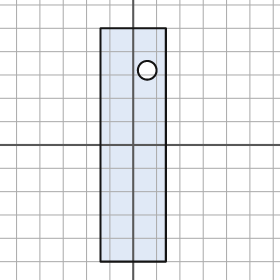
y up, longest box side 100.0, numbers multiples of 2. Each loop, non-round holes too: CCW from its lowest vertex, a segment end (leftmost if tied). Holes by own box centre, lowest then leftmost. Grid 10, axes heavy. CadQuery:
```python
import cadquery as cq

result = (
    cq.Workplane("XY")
    .moveTo(-14.0, -50.0)
    .lineTo(14.0, -50.0)
    .lineTo(14.0, 50.0)
    .lineTo(-14.0, 50.0)
    .close()
    .moveTo(6.0, 32.0)
    .circle(4.0)
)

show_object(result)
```